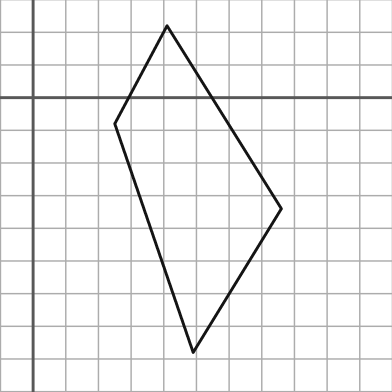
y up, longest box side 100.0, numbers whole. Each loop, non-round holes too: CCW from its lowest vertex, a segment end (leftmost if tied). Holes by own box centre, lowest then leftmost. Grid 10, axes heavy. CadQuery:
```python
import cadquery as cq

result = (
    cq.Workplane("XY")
    .moveTo(49.0, -78.0)
    .lineTo(76.0, -34.0)
    .lineTo(41.0, 22.0)
    .lineTo(25.0, -8.0)
    .close()
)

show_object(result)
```